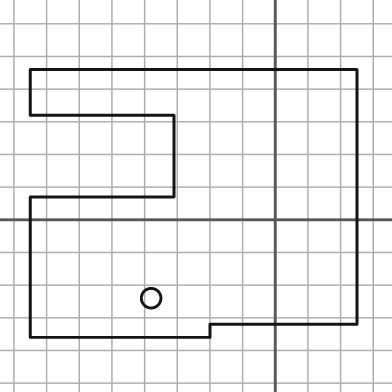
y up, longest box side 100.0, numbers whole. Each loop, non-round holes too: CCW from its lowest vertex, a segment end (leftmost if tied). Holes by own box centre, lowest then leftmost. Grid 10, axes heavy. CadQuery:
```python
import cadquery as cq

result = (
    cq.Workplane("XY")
    .moveTo(-75.0, -36.0)
    .lineTo(-20.0, -36.0)
    .lineTo(-20.0, -32.0)
    .lineTo(25.0, -32.0)
    .lineTo(25.0, 46.0)
    .lineTo(-75.0, 46.0)
    .lineTo(-75.0, 32.0)
    .lineTo(-31.0, 32.0)
    .lineTo(-31.0, 7.0)
    .lineTo(-75.0, 7.0)
    .close()
    .moveTo(-38.0, -24.0)
    .circle(3.0)
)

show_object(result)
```